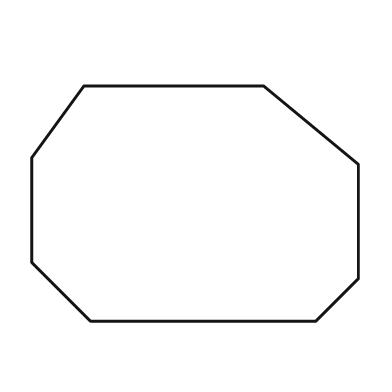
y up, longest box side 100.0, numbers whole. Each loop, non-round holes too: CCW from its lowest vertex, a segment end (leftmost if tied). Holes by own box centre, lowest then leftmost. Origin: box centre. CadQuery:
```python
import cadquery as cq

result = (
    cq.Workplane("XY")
    .moveTo(-32.0, -36.0)
    .lineTo(37.0, -36.0)
    .lineTo(50.0, -23.0)
    .lineTo(50.0, 12.0)
    .lineTo(21.0, 36.0)
    .lineTo(-34.0, 36.0)
    .lineTo(-50.0, 14.0)
    .lineTo(-50.0, -18.0)
    .close()
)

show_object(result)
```